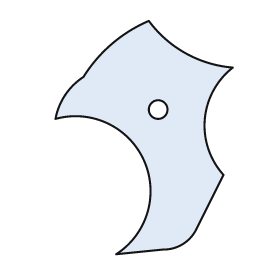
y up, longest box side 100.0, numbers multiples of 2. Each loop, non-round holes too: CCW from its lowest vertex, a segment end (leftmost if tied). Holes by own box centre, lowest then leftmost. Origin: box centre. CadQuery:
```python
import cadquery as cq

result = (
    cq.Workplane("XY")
    .moveTo(-12.0, -50.0)
    .lineTo(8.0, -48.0)
    .threePointArc((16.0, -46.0), (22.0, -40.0))
    .lineTo(34.0, -16.0)
    .threePointArc((26.0, 8.0), (38.0, 30.0))
    .threePointArc((18.0, 36.0), (2.0, 50.0))
    .threePointArc((-14.0, 40.0), (-26.0, 26.0))
    .threePointArc((-34.0, 18.0), (-38.0, 8.0))
    .threePointArc((0.0, -10.0), (-12.0, -50.0))
    .close()
    .moveTo(6.0, 12.0)
    .circle(4.0)
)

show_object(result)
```